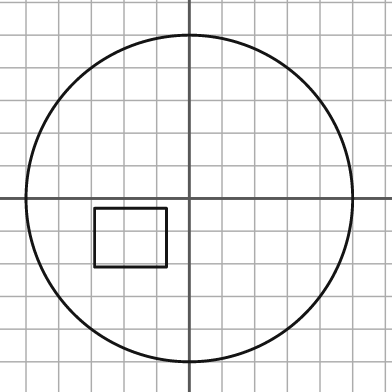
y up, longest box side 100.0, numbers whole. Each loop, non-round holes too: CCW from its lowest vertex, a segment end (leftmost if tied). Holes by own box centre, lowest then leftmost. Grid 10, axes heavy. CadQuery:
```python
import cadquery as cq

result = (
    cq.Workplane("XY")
    .moveTo(0.0, 0.0)
    .circle(50.0)
    .moveTo(-29.0, -21.0)
    .lineTo(-7.0, -21.0)
    .lineTo(-7.0, -3.0)
    .lineTo(-29.0, -3.0)
    .close()
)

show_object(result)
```